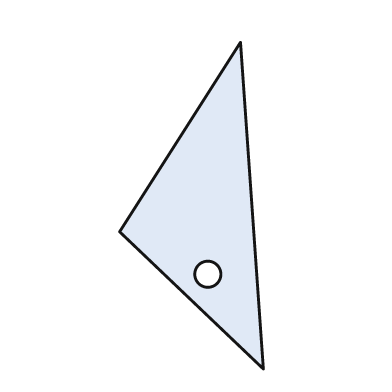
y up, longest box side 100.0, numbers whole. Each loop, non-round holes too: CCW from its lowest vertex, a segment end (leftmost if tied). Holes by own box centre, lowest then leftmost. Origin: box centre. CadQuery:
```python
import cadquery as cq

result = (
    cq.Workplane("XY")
    .moveTo(22.0, -50.0)
    .lineTo(15.0, 50.0)
    .lineTo(-22.0, -8.0)
    .close()
    .moveTo(5.0, -21.0)
    .circle(4.0)
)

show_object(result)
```